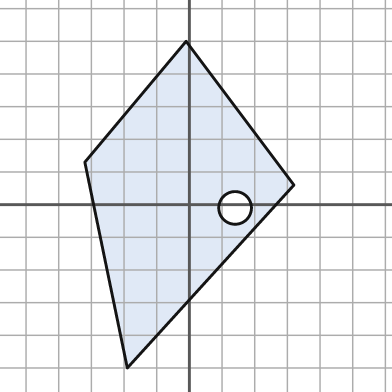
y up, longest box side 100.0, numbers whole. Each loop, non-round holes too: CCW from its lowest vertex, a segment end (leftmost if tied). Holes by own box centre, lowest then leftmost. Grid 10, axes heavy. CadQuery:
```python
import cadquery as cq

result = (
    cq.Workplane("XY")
    .moveTo(-19.0, -50.0)
    .lineTo(32.0, 6.0)
    .lineTo(-1.0, 50.0)
    .lineTo(-32.0, 13.0)
    .close()
    .moveTo(14.0, -1.0)
    .circle(5.0)
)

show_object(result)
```